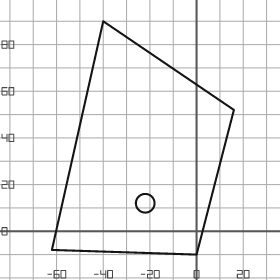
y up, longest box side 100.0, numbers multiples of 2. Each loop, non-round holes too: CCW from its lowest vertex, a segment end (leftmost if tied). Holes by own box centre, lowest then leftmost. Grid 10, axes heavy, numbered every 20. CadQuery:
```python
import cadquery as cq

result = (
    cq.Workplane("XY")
    .moveTo(0.0, -10.0)
    .lineTo(16.0, 52.0)
    .lineTo(-40.0, 90.0)
    .lineTo(-62.0, -8.0)
    .close()
    .moveTo(-22.0, 12.0)
    .circle(4.0)
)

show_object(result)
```